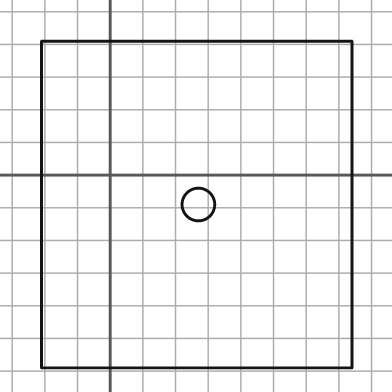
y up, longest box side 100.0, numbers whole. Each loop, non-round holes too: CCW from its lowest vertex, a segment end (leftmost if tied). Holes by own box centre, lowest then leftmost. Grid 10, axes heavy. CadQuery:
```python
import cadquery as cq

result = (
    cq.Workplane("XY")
    .moveTo(-21.0, -59.0)
    .lineTo(74.0, -59.0)
    .lineTo(74.0, 41.0)
    .lineTo(-21.0, 41.0)
    .close()
    .moveTo(27.0, -9.0)
    .circle(5.0)
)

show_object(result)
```